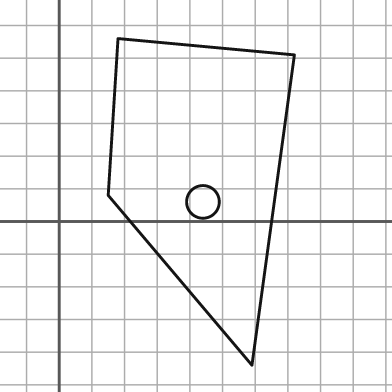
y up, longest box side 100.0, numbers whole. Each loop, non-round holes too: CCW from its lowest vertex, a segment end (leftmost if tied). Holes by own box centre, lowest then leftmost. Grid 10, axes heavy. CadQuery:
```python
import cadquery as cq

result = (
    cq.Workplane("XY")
    .moveTo(59.0, -44.0)
    .lineTo(72.0, 51.0)
    .lineTo(18.0, 56.0)
    .lineTo(15.0, 8.0)
    .close()
    .moveTo(44.0, 6.0)
    .circle(5.0)
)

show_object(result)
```